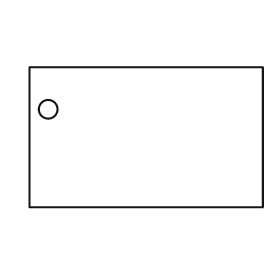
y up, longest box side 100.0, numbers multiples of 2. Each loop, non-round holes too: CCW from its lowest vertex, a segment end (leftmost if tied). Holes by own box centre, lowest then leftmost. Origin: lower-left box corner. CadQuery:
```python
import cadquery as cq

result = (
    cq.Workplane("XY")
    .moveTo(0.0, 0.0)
    .lineTo(100.0, 0.0)
    .lineTo(100.0, 60.0)
    .lineTo(0.0, 60.0)
    .close()
    .moveTo(8.0, 42.0)
    .circle(4.0)
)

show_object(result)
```